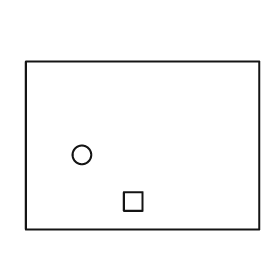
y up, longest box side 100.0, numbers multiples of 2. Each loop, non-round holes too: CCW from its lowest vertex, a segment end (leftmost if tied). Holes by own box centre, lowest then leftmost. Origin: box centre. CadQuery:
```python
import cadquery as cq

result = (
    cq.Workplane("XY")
    .moveTo(-50.0, -36.0)
    .lineTo(50.0, -36.0)
    .lineTo(50.0, 36.0)
    .lineTo(-50.0, 36.0)
    .close()
    .moveTo(-8.0, -28.0)
    .lineTo(0.0, -28.0)
    .lineTo(0.0, -20.0)
    .lineTo(-8.0, -20.0)
    .close()
    .moveTo(-26.0, -4.0)
    .circle(4.0)
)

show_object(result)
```